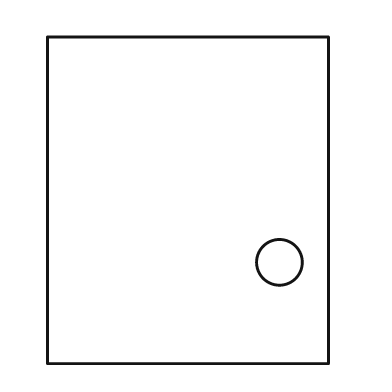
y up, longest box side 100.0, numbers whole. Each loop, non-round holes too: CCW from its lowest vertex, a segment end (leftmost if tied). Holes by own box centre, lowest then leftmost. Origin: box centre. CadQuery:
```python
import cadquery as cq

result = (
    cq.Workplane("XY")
    .moveTo(-43.0, -50.0)
    .lineTo(43.0, -50.0)
    .lineTo(43.0, 50.0)
    .lineTo(-43.0, 50.0)
    .close()
    .moveTo(28.0, -19.0)
    .circle(7.0)
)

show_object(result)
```